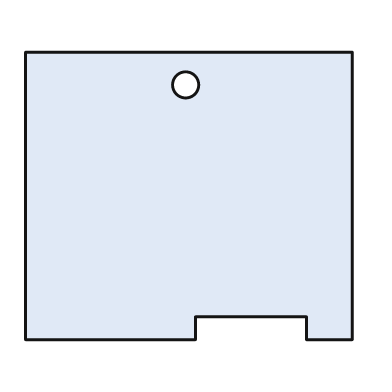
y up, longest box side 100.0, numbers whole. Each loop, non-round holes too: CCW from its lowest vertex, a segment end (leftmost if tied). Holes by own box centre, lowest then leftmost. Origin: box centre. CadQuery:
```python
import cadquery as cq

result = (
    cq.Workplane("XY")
    .moveTo(-50.0, -44.0)
    .lineTo(2.0, -44.0)
    .lineTo(2.0, -37.0)
    .lineTo(36.0, -37.0)
    .lineTo(36.0, -44.0)
    .lineTo(50.0, -44.0)
    .lineTo(50.0, 44.0)
    .lineTo(-50.0, 44.0)
    .close()
    .moveTo(-1.0, 34.0)
    .circle(4.0)
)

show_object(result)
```